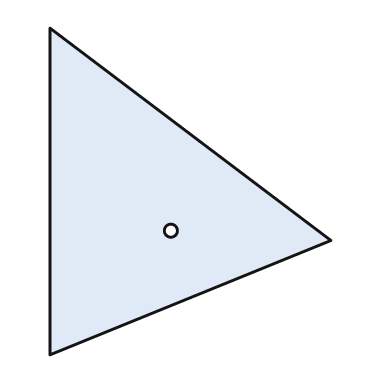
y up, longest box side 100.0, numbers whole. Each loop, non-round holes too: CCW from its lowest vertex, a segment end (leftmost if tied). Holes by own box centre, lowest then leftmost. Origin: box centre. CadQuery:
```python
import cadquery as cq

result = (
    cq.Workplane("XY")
    .moveTo(-43.0, -50.0)
    .lineTo(43.0, -15.0)
    .lineTo(-43.0, 50.0)
    .close()
    .moveTo(-6.0, -12.0)
    .circle(2.0)
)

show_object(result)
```